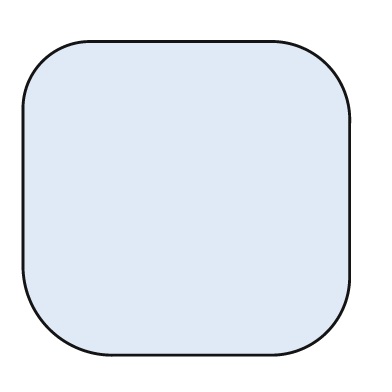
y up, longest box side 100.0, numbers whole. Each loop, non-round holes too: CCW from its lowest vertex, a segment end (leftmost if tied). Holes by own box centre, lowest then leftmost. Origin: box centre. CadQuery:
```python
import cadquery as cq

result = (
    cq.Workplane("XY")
    .moveTo(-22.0, -48.0)
    .lineTo(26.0, -48.0)
    .threePointArc((43.0, -41.0), (50.0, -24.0))
    .lineTo(50.0, 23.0)
    .threePointArc((43.0, 41.0), (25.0, 48.0))
    .lineTo(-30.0, 48.0)
    .threePointArc((-44.0, 42.0), (-50.0, 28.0))
    .lineTo(-50.0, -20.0)
    .threePointArc((-42.0, -40.0), (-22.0, -48.0))
    .close()
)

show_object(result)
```